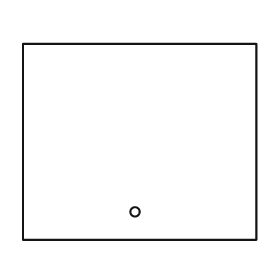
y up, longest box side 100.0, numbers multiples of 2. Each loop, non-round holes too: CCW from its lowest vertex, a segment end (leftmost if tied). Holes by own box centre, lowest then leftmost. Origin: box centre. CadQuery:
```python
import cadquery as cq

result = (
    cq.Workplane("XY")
    .moveTo(-50.0, -42.0)
    .lineTo(50.0, -42.0)
    .lineTo(50.0, 42.0)
    .lineTo(-50.0, 42.0)
    .close()
    .moveTo(-2.0, -30.0)
    .circle(2.0)
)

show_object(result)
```